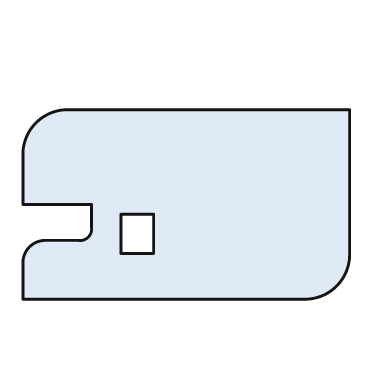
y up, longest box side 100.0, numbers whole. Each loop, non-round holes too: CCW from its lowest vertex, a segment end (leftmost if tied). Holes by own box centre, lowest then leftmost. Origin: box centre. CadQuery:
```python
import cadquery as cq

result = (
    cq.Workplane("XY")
    .moveTo(-50.0, -29.0)
    .lineTo(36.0, -29.0)
    .threePointArc((46.0, -25.0), (50.0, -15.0))
    .lineTo(50.0, 29.0)
    .lineTo(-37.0, 29.0)
    .threePointArc((-46.0, 25.0), (-50.0, 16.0))
    .lineTo(-50.0, 0.0)
    .lineTo(-29.0, 0.0)
    .lineTo(-29.0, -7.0)
    .threePointArc((-30.0, -10.0), (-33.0, -11.0))
    .lineTo(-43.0, -11.0)
    .threePointArc((-48.0, -13.0), (-50.0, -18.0))
    .close()
    .moveTo(-20.0, -15.0)
    .lineTo(-10.0, -15.0)
    .lineTo(-10.0, -3.0)
    .lineTo(-20.0, -3.0)
    .close()
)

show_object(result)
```